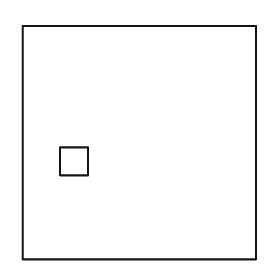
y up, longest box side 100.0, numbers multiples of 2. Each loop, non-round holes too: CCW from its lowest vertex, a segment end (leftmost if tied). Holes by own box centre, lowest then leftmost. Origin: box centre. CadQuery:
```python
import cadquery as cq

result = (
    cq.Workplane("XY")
    .moveTo(-50.0, -50.0)
    .lineTo(50.0, -50.0)
    .lineTo(50.0, 50.0)
    .lineTo(-50.0, 50.0)
    .close()
    .moveTo(-34.0, -14.0)
    .lineTo(-22.0, -14.0)
    .lineTo(-22.0, -2.0)
    .lineTo(-34.0, -2.0)
    .close()
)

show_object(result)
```